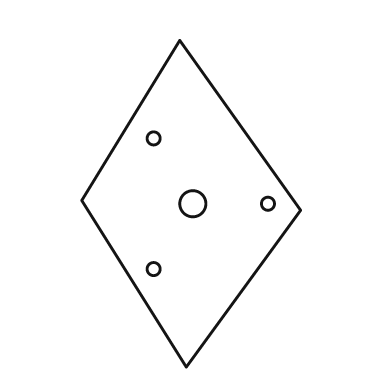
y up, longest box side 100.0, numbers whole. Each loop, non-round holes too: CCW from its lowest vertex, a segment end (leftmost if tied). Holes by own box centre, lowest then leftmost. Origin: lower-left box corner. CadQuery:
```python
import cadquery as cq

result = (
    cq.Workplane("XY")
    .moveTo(32.0, 0.0)
    .lineTo(67.0, 48.0)
    .lineTo(30.0, 100.0)
    .lineTo(0.0, 51.0)
    .close()
    .moveTo(22.0, 30.0)
    .circle(2.0)
    .moveTo(34.0, 50.0)
    .circle(4.0)
    .moveTo(57.0, 50.0)
    .circle(2.0)
    .moveTo(22.0, 70.0)
    .circle(2.0)
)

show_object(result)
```